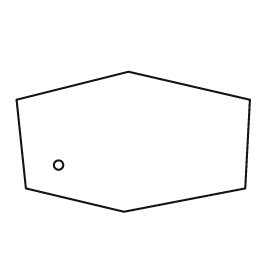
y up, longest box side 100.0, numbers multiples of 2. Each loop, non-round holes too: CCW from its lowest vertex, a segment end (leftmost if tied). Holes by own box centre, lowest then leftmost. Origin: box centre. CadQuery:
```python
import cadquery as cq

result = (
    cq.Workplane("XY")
    .moveTo(-4.0, -30.0)
    .lineTo(48.0, -20.0)
    .lineTo(50.0, 18.0)
    .lineTo(-2.0, 30.0)
    .lineTo(-50.0, 18.0)
    .lineTo(-46.0, -20.0)
    .close()
    .moveTo(-32.0, -10.0)
    .circle(2.0)
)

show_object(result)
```